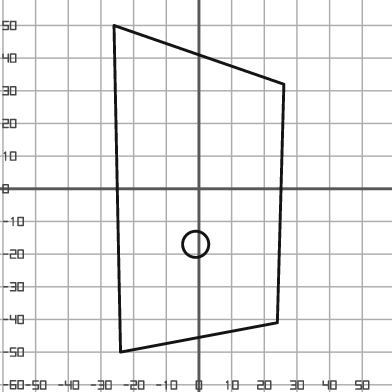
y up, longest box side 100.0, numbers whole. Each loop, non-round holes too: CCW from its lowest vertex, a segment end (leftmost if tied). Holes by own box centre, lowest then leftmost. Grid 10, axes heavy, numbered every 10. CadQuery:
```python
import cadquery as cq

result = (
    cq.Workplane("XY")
    .moveTo(-24.0, -50.0)
    .lineTo(24.0, -41.0)
    .lineTo(26.0, 32.0)
    .lineTo(-26.0, 50.0)
    .close()
    .moveTo(-1.0, -17.0)
    .circle(4.0)
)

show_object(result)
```